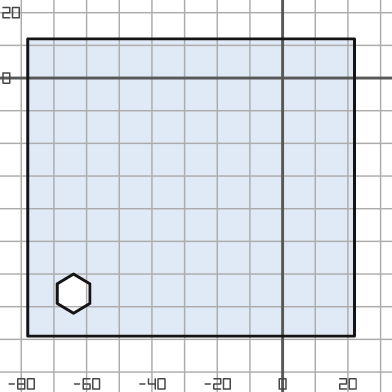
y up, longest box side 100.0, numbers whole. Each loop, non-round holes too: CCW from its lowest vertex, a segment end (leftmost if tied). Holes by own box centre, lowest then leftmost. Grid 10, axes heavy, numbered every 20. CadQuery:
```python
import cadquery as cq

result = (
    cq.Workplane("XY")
    .moveTo(-78.0, -79.0)
    .lineTo(22.0, -79.0)
    .lineTo(22.0, 12.0)
    .lineTo(-78.0, 12.0)
    .close()
    .moveTo(-64.0, -72.0)
    .lineTo(-59.0, -69.0)
    .lineTo(-59.0, -63.0)
    .lineTo(-64.0, -60.0)
    .lineTo(-69.0, -63.0)
    .lineTo(-69.0, -69.0)
    .close()
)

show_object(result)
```